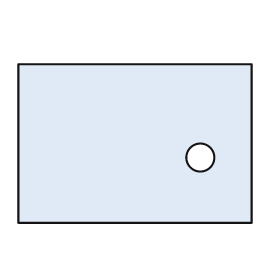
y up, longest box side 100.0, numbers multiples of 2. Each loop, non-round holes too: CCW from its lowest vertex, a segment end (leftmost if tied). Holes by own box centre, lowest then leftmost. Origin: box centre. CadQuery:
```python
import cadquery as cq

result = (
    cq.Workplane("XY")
    .moveTo(-50.0, -34.0)
    .lineTo(50.0, -34.0)
    .lineTo(50.0, 34.0)
    .lineTo(-50.0, 34.0)
    .close()
    .moveTo(28.0, -6.0)
    .circle(6.0)
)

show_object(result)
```